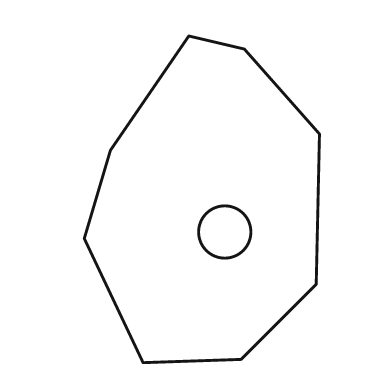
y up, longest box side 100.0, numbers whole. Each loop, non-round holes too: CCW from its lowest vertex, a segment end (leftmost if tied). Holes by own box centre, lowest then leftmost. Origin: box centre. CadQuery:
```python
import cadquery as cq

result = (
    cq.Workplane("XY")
    .moveTo(-18.0, -50.0)
    .lineTo(12.0, -49.0)
    .lineTo(35.0, -26.0)
    .lineTo(36.0, 20.0)
    .lineTo(13.0, 46.0)
    .lineTo(-4.0, 50.0)
    .lineTo(-28.0, 15.0)
    .lineTo(-36.0, -12.0)
    .close()
    .moveTo(7.0, -10.0)
    .circle(8.0)
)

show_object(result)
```